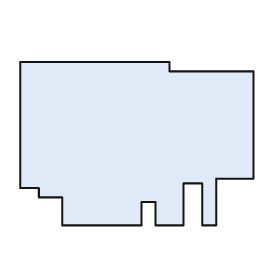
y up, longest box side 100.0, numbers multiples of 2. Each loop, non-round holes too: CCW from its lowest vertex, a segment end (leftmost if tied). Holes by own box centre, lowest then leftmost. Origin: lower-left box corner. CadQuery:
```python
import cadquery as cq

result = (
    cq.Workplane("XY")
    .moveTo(18.0, 0.0)
    .lineTo(52.0, 0.0)
    .lineTo(52.0, 10.0)
    .lineTo(58.0, 10.0)
    .lineTo(58.0, 0.0)
    .lineTo(70.0, 0.0)
    .lineTo(70.0, 18.0)
    .lineTo(78.0, 18.0)
    .lineTo(78.0, 0.0)
    .lineTo(84.0, 0.0)
    .lineTo(84.0, 20.0)
    .lineTo(100.0, 20.0)
    .lineTo(100.0, 66.0)
    .lineTo(64.0, 66.0)
    .lineTo(64.0, 70.0)
    .lineTo(0.0, 70.0)
    .lineTo(0.0, 16.0)
    .lineTo(8.0, 16.0)
    .lineTo(8.0, 12.0)
    .lineTo(18.0, 12.0)
    .close()
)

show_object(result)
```